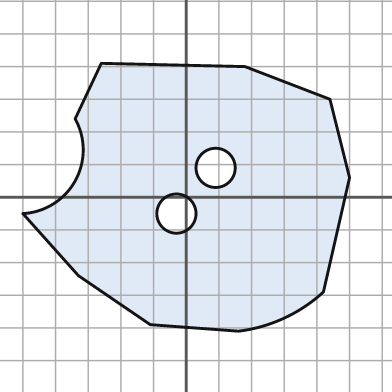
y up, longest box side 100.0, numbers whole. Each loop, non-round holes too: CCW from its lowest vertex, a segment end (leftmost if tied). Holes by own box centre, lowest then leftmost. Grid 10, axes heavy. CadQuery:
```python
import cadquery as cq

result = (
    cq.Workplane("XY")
    .moveTo(16.0, -41.0)
    .threePointArc((30.0, -37.0), (42.0, -29.0))
    .lineTo(50.0, 6.0)
    .lineTo(44.0, 30.0)
    .lineTo(18.0, 40.0)
    .lineTo(-26.0, 41.0)
    .lineTo(-34.0, 24.0)
    .threePointArc((-34.0, 5.0), (-50.0, -5.0))
    .lineTo(-33.0, -24.0)
    .lineTo(-11.0, -39.0)
    .close()
    .moveTo(-3.0, -5.0)
    .circle(6.0)
    .moveTo(9.0, 9.0)
    .circle(6.0)
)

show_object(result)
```